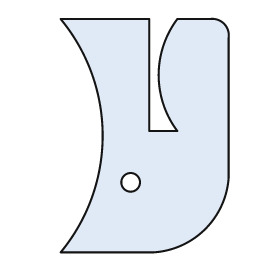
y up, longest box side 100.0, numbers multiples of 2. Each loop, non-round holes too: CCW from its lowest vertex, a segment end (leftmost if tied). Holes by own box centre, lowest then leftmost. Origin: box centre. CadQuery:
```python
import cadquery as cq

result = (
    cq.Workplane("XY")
    .moveTo(-36.0, -50.0)
    .lineTo(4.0, -50.0)
    .threePointArc((26.0, -40.0), (36.0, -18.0))
    .lineTo(36.0, 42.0)
    .threePointArc((34.0, 48.0), (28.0, 50.0))
    .lineTo(14.0, 50.0)
    .threePointArc((6.0, 26.0), (14.0, 2.0))
    .lineTo(2.0, 2.0)
    .lineTo(2.0, 50.0)
    .lineTo(-36.0, 50.0)
    .threePointArc((-18.0, 0.0), (-36.0, -50.0))
    .close()
    .moveTo(-6.0, -20.0)
    .circle(4.0)
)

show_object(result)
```